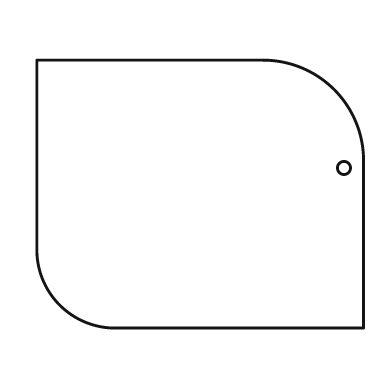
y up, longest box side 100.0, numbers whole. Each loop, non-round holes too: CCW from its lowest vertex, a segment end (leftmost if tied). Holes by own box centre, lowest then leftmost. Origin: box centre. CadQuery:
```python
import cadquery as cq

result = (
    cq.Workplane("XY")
    .moveTo(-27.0, -41.0)
    .lineTo(50.0, -41.0)
    .lineTo(50.0, 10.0)
    .threePointArc((41.0, 32.0), (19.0, 41.0))
    .lineTo(-50.0, 41.0)
    .lineTo(-50.0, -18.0)
    .threePointArc((-43.0, -34.0), (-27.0, -41.0))
    .close()
    .moveTo(44.0, 8.0)
    .circle(2.0)
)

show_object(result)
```